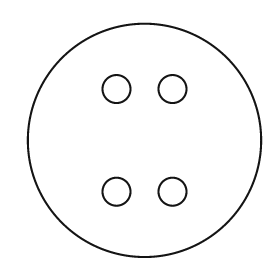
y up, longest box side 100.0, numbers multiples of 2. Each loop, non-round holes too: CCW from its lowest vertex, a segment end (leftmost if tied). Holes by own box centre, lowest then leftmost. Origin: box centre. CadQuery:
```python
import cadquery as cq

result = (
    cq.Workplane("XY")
    .moveTo(0.0, 0.0)
    .circle(50.0)
    .moveTo(-12.0, -22.0)
    .circle(6.0)
    .moveTo(12.0, -22.0)
    .circle(6.0)
    .moveTo(-12.0, 22.0)
    .circle(6.0)
    .moveTo(12.0, 22.0)
    .circle(6.0)
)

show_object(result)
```